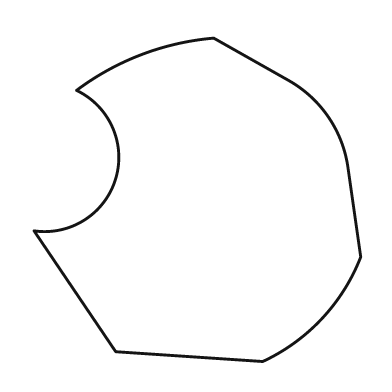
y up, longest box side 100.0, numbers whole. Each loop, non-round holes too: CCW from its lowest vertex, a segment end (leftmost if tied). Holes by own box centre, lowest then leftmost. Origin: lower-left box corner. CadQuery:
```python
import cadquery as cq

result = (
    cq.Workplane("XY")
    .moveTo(70.0, 0.0)
    .threePointArc((88.0, 13.0), (100.0, 32.0))
    .lineTo(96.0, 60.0)
    .threePointArc((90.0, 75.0), (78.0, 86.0))
    .lineTo(55.0, 99.0)
    .threePointArc((33.0, 94.0), (13.0, 83.0))
    .threePointArc((25.0, 56.0), (0.0, 40.0))
    .lineTo(25.0, 3.0)
    .close()
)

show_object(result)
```